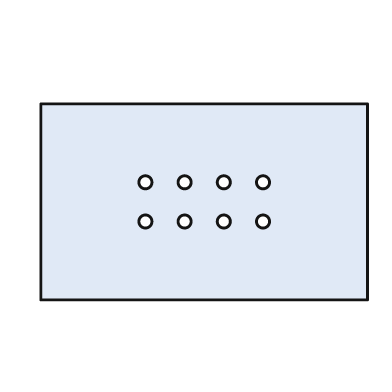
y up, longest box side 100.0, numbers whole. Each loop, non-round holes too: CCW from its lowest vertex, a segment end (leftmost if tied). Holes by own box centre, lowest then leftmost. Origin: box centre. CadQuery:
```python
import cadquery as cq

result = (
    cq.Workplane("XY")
    .moveTo(-50.0, -30.0)
    .lineTo(50.0, -30.0)
    .lineTo(50.0, 30.0)
    .lineTo(-50.0, 30.0)
    .close()
    .moveTo(-18.0, -6.0)
    .circle(2.0)
    .moveTo(-6.0, -6.0)
    .circle(2.0)
    .moveTo(6.0, -6.0)
    .circle(2.0)
    .moveTo(18.0, -6.0)
    .circle(2.0)
    .moveTo(-18.0, 6.0)
    .circle(2.0)
    .moveTo(-6.0, 6.0)
    .circle(2.0)
    .moveTo(6.0, 6.0)
    .circle(2.0)
    .moveTo(18.0, 6.0)
    .circle(2.0)
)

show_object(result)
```